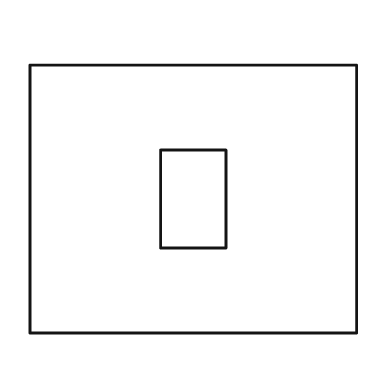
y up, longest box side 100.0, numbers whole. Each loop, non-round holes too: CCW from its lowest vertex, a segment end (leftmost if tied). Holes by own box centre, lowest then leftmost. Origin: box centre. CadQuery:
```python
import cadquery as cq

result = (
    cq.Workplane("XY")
    .moveTo(-50.0, -41.0)
    .lineTo(50.0, -41.0)
    .lineTo(50.0, 41.0)
    .lineTo(-50.0, 41.0)
    .close()
    .moveTo(-10.0, -15.0)
    .lineTo(10.0, -15.0)
    .lineTo(10.0, 15.0)
    .lineTo(-10.0, 15.0)
    .close()
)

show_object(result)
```